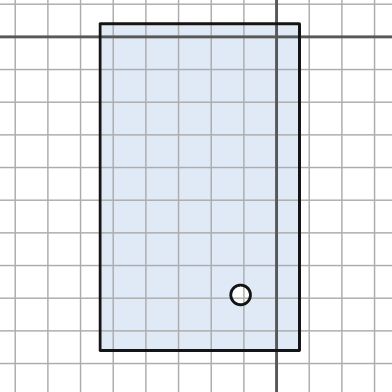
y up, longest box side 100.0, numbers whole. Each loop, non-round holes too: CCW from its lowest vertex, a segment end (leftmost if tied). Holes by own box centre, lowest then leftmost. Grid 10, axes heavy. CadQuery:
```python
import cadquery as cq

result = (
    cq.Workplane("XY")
    .moveTo(-54.0, -96.0)
    .lineTo(7.0, -96.0)
    .lineTo(7.0, 4.0)
    .lineTo(-54.0, 4.0)
    .close()
    .moveTo(-11.0, -79.0)
    .circle(3.0)
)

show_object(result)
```